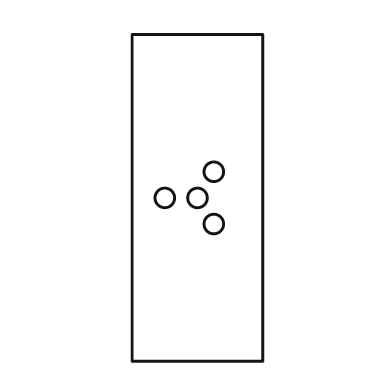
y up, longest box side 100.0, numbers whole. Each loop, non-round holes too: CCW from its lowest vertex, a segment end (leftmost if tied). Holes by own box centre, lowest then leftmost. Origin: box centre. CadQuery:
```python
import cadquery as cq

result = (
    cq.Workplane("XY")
    .moveTo(-20.0, -50.0)
    .lineTo(20.0, -50.0)
    .lineTo(20.0, 50.0)
    .lineTo(-20.0, 50.0)
    .close()
    .moveTo(5.0, -8.0)
    .circle(3.0)
    .moveTo(-10.0, 0.0)
    .circle(3.0)
    .moveTo(0.0, 0.0)
    .circle(3.0)
    .moveTo(5.0, 8.0)
    .circle(3.0)
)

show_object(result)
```